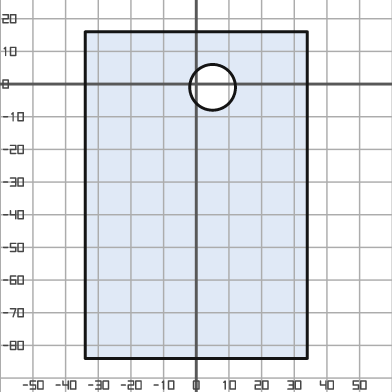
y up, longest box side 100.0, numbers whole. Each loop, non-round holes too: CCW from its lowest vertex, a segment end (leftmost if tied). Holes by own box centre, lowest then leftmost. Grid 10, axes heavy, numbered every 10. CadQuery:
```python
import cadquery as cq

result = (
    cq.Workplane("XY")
    .moveTo(-34.0, -84.0)
    .lineTo(34.0, -84.0)
    .lineTo(34.0, 16.0)
    .lineTo(-34.0, 16.0)
    .close()
    .moveTo(5.0, -1.0)
    .circle(7.0)
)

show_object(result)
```